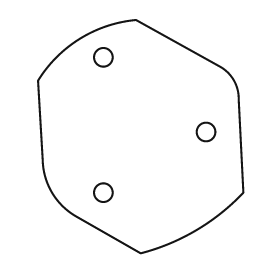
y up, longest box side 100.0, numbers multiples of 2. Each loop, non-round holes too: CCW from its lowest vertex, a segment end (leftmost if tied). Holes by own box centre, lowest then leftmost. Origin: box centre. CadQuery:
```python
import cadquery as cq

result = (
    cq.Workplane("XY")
    .moveTo(0.0, -50.0)
    .threePointArc((24.0, -40.0), (44.0, -24.0))
    .lineTo(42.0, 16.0)
    .threePointArc((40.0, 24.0), (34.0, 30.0))
    .lineTo(-2.0, 50.0)
    .threePointArc((-26.0, 42.0), (-44.0, 24.0))
    .lineTo(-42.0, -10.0)
    .threePointArc((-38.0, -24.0), (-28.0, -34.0))
    .close()
    .moveTo(-16.0, -24.0)
    .circle(4.0)
    .moveTo(28.0, 2.0)
    .circle(4.0)
    .moveTo(-16.0, 34.0)
    .circle(4.0)
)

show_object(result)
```